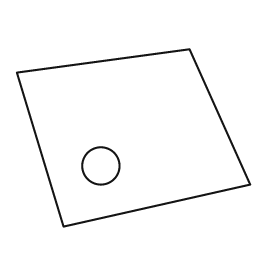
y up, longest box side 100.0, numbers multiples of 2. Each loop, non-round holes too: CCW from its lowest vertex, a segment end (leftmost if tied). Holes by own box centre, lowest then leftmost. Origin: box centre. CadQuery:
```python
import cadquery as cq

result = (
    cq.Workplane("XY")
    .moveTo(-30.0, -38.0)
    .lineTo(50.0, -20.0)
    .lineTo(24.0, 38.0)
    .lineTo(-50.0, 28.0)
    .close()
    .moveTo(-14.0, -12.0)
    .circle(8.0)
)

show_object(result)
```